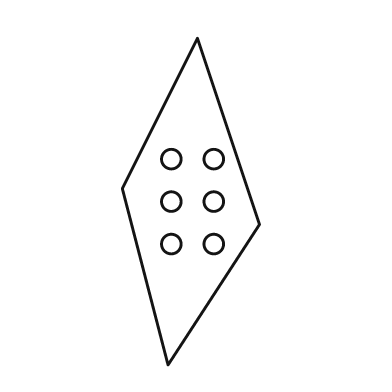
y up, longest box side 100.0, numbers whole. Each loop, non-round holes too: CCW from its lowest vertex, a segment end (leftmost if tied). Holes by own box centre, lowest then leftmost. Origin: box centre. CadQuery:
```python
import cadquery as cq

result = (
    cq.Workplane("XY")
    .moveTo(-7.0, -50.0)
    .lineTo(21.0, -7.0)
    .lineTo(2.0, 50.0)
    .lineTo(-21.0, 4.0)
    .close()
    .moveTo(-6.0, -13.0)
    .circle(3.0)
    .moveTo(7.0, -13.0)
    .circle(3.0)
    .moveTo(-6.0, 0.0)
    .circle(3.0)
    .moveTo(7.0, 0.0)
    .circle(3.0)
    .moveTo(-6.0, 13.0)
    .circle(3.0)
    .moveTo(7.0, 13.0)
    .circle(3.0)
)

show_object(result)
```